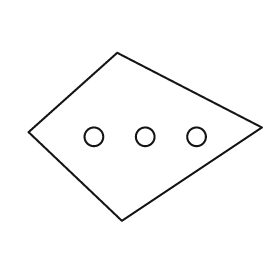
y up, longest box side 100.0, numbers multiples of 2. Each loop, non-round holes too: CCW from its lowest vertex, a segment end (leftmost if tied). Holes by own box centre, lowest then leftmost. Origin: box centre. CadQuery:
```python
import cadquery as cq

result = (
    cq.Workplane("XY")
    .moveTo(-10.0, -36.0)
    .lineTo(50.0, 4.0)
    .lineTo(-12.0, 36.0)
    .lineTo(-50.0, 2.0)
    .close()
    .moveTo(-22.0, 0.0)
    .circle(4.0)
    .moveTo(0.0, 0.0)
    .circle(4.0)
    .moveTo(22.0, 0.0)
    .circle(4.0)
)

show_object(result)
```